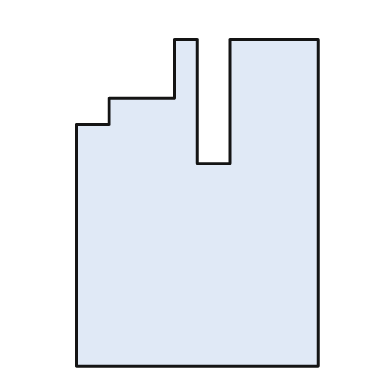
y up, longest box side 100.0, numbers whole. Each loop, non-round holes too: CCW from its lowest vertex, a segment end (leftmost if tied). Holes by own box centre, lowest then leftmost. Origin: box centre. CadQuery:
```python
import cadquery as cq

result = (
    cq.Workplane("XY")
    .moveTo(-37.0, -50.0)
    .lineTo(37.0, -50.0)
    .lineTo(37.0, 50.0)
    .lineTo(10.0, 50.0)
    .lineTo(10.0, 12.0)
    .lineTo(0.0, 12.0)
    .lineTo(0.0, 50.0)
    .lineTo(-7.0, 50.0)
    .lineTo(-7.0, 32.0)
    .lineTo(-27.0, 32.0)
    .lineTo(-27.0, 24.0)
    .lineTo(-37.0, 24.0)
    .close()
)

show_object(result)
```